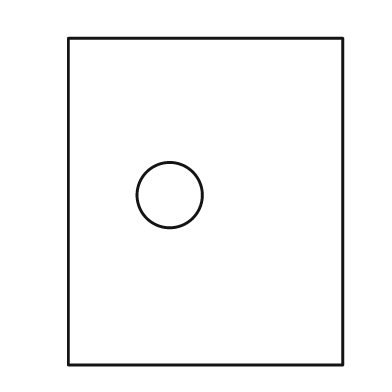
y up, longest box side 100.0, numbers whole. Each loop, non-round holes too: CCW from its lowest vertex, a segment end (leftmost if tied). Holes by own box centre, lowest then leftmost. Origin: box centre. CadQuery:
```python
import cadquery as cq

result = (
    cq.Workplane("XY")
    .moveTo(-42.0, -50.0)
    .lineTo(42.0, -50.0)
    .lineTo(42.0, 50.0)
    .lineTo(-42.0, 50.0)
    .close()
    .moveTo(-11.0, 2.0)
    .circle(10.0)
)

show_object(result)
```